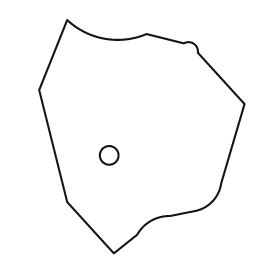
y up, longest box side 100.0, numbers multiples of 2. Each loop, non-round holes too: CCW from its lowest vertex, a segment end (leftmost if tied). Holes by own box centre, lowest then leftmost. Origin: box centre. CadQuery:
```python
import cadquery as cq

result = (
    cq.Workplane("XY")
    .moveTo(-12.0, -50.0)
    .lineTo(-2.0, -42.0)
    .threePointArc((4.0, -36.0), (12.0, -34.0))
    .lineTo(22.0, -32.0)
    .threePointArc((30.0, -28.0), (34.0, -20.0))
    .lineTo(44.0, 14.0)
    .lineTo(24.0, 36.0)
    .threePointArc((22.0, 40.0), (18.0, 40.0))
    .lineTo(2.0, 44.0)
    .threePointArc((-16.0, 42.0), (-32.0, 50.0))
    .lineTo(-44.0, 20.0)
    .lineTo(-32.0, -28.0)
    .close()
    .moveTo(-14.0, -8.0)
    .circle(4.0)
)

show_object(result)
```